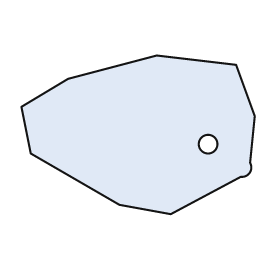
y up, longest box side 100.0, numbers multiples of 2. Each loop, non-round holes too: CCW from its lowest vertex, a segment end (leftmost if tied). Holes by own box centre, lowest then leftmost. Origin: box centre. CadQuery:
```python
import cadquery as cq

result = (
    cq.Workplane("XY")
    .moveTo(14.0, -34.0)
    .lineTo(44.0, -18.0)
    .threePointArc((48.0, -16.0), (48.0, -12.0))
    .lineTo(50.0, 8.0)
    .lineTo(42.0, 30.0)
    .lineTo(8.0, 34.0)
    .lineTo(-30.0, 24.0)
    .lineTo(-50.0, 12.0)
    .lineTo(-46.0, -8.0)
    .lineTo(-8.0, -30.0)
    .close()
    .moveTo(30.0, -4.0)
    .circle(4.0)
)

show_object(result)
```